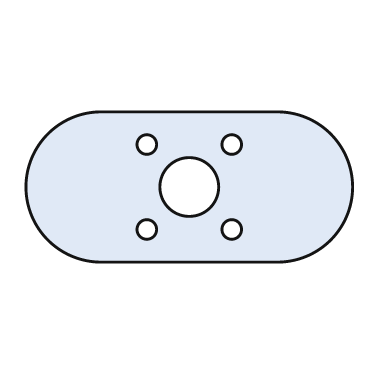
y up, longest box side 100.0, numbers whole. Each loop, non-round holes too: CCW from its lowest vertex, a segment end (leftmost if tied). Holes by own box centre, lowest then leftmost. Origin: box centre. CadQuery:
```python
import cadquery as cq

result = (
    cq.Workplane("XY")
    .moveTo(-27.0, -23.0)
    .lineTo(27.0, -23.0)
    .threePointArc((50.0, 0.0), (27.0, 23.0))
    .lineTo(-27.0, 23.0)
    .threePointArc((-50.0, 0.0), (-27.0, -23.0))
    .close()
    .moveTo(-13.0, -13.0)
    .circle(3.0)
    .moveTo(13.0, -13.0)
    .circle(3.0)
    .moveTo(0.0, 0.0)
    .circle(9.0)
    .moveTo(-13.0, 13.0)
    .circle(3.0)
    .moveTo(13.0, 13.0)
    .circle(3.0)
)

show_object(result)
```